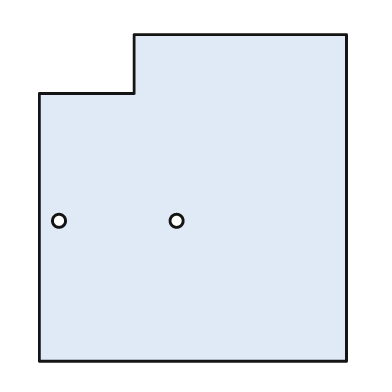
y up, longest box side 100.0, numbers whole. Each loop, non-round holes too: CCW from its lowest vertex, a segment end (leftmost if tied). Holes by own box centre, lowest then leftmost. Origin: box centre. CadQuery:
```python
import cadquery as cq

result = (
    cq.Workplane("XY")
    .moveTo(-47.0, -50.0)
    .lineTo(47.0, -50.0)
    .lineTo(47.0, 50.0)
    .lineTo(-18.0, 50.0)
    .lineTo(-18.0, 32.0)
    .lineTo(-47.0, 32.0)
    .close()
    .moveTo(-41.0, -7.0)
    .circle(2.0)
    .moveTo(-5.0, -7.0)
    .circle(2.0)
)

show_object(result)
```